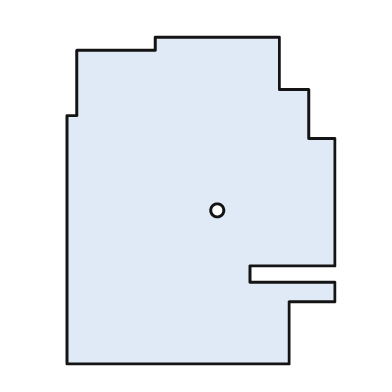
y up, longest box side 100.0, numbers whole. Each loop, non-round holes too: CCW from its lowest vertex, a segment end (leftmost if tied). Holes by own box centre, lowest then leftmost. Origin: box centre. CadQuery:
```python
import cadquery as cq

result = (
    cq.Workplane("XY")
    .moveTo(-41.0, -50.0)
    .lineTo(27.0, -50.0)
    .lineTo(27.0, -31.0)
    .lineTo(41.0, -31.0)
    .lineTo(41.0, -25.0)
    .lineTo(15.0, -25.0)
    .lineTo(15.0, -20.0)
    .lineTo(41.0, -20.0)
    .lineTo(41.0, 19.0)
    .lineTo(33.0, 19.0)
    .lineTo(33.0, 34.0)
    .lineTo(24.0, 34.0)
    .lineTo(24.0, 50.0)
    .lineTo(-14.0, 50.0)
    .lineTo(-14.0, 46.0)
    .lineTo(-38.0, 46.0)
    .lineTo(-38.0, 26.0)
    .lineTo(-41.0, 26.0)
    .close()
    .moveTo(5.0, -3.0)
    .circle(2.0)
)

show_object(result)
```